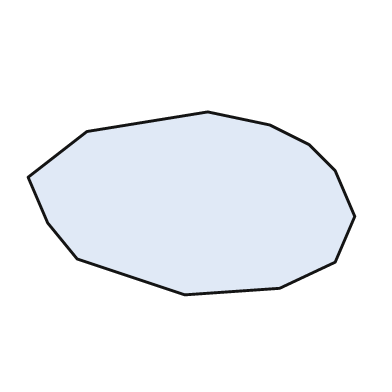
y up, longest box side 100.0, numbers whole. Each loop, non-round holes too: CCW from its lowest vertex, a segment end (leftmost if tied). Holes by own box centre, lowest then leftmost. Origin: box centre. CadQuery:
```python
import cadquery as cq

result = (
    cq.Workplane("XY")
    .moveTo(-2.0, -28.0)
    .lineTo(27.0, -26.0)
    .lineTo(44.0, -18.0)
    .lineTo(50.0, -4.0)
    .lineTo(44.0, 10.0)
    .lineTo(36.0, 18.0)
    .lineTo(24.0, 24.0)
    .lineTo(5.0, 28.0)
    .lineTo(-32.0, 22.0)
    .lineTo(-50.0, 8.0)
    .lineTo(-44.0, -6.0)
    .lineTo(-35.0, -17.0)
    .close()
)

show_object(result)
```